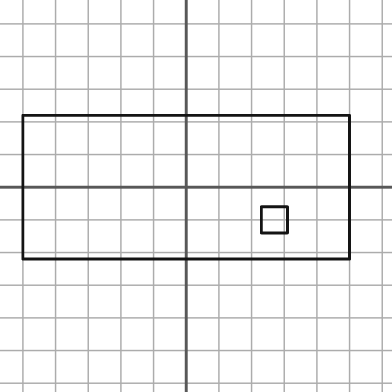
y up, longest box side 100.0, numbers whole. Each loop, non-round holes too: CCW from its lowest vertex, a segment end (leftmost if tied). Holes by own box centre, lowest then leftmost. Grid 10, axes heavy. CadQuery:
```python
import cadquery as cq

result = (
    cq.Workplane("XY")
    .moveTo(-50.0, -22.0)
    .lineTo(50.0, -22.0)
    .lineTo(50.0, 22.0)
    .lineTo(-50.0, 22.0)
    .close()
    .moveTo(23.0, -14.0)
    .lineTo(31.0, -14.0)
    .lineTo(31.0, -6.0)
    .lineTo(23.0, -6.0)
    .close()
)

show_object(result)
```